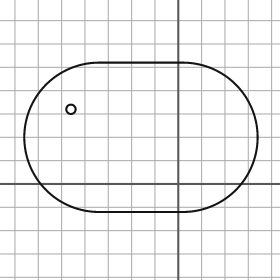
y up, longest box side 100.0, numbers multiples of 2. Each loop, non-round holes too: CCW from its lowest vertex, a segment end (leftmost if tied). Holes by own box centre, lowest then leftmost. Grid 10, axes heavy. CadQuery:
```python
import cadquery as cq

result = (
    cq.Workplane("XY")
    .moveTo(-34.0, -12.0)
    .lineTo(2.0, -12.0)
    .threePointArc((34.0, 20.0), (2.0, 52.0))
    .lineTo(-34.0, 52.0)
    .threePointArc((-66.0, 20.0), (-34.0, -12.0))
    .close()
    .moveTo(-46.0, 32.0)
    .circle(2.0)
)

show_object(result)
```